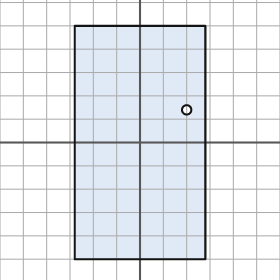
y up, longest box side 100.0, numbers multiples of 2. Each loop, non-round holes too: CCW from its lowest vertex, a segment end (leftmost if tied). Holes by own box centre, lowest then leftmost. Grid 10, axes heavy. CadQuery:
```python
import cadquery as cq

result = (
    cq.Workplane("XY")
    .moveTo(-28.0, -50.0)
    .lineTo(28.0, -50.0)
    .lineTo(28.0, 50.0)
    .lineTo(-28.0, 50.0)
    .close()
    .moveTo(20.0, 14.0)
    .circle(2.0)
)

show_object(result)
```